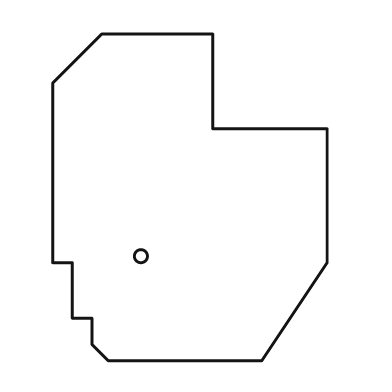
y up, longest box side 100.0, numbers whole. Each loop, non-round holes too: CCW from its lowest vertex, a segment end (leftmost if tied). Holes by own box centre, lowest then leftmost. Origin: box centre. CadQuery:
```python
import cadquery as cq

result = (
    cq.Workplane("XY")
    .moveTo(-25.0, -50.0)
    .lineTo(22.0, -50.0)
    .lineTo(42.0, -20.0)
    .lineTo(42.0, 21.0)
    .lineTo(7.0, 21.0)
    .lineTo(7.0, 50.0)
    .lineTo(-27.0, 50.0)
    .lineTo(-42.0, 35.0)
    .lineTo(-42.0, -20.0)
    .lineTo(-36.0, -20.0)
    .lineTo(-36.0, -37.0)
    .lineTo(-30.0, -37.0)
    .lineTo(-30.0, -45.0)
    .close()
    .moveTo(-15.0, -18.0)
    .circle(2.0)
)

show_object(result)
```